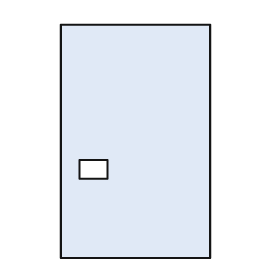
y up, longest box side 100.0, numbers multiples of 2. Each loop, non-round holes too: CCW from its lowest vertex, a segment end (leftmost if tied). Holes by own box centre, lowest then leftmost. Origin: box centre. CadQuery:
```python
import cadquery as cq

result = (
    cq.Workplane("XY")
    .moveTo(-32.0, -50.0)
    .lineTo(32.0, -50.0)
    .lineTo(32.0, 50.0)
    .lineTo(-32.0, 50.0)
    .close()
    .moveTo(-24.0, -16.0)
    .lineTo(-12.0, -16.0)
    .lineTo(-12.0, -8.0)
    .lineTo(-24.0, -8.0)
    .close()
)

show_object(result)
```